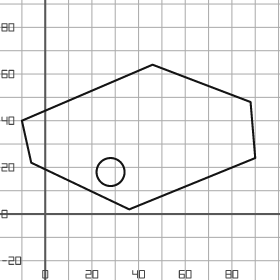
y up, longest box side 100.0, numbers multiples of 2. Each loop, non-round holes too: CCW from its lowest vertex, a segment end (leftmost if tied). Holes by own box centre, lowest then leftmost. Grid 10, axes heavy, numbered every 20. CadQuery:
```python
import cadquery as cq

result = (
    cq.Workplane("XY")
    .moveTo(36.0, 2.0)
    .lineTo(90.0, 24.0)
    .lineTo(88.0, 48.0)
    .lineTo(46.0, 64.0)
    .lineTo(-10.0, 40.0)
    .lineTo(-6.0, 22.0)
    .close()
    .moveTo(28.0, 18.0)
    .circle(6.0)
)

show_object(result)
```